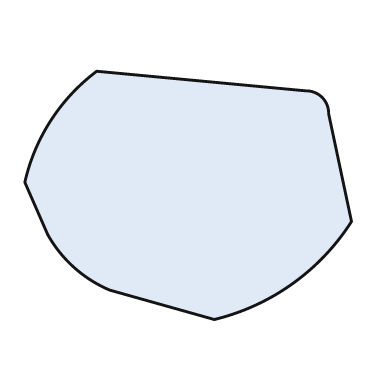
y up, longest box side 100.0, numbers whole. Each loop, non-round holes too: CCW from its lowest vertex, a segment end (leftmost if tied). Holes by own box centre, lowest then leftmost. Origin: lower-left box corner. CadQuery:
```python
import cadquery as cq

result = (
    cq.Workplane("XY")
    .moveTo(58.0, 0.0)
    .threePointArc((82.0, 11.0), (100.0, 30.0))
    .lineTo(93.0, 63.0)
    .threePointArc((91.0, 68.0), (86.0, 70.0))
    .lineTo(22.0, 76.0)
    .threePointArc((8.0, 61.0), (0.0, 42.0))
    .lineTo(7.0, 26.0)
    .threePointArc((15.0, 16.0), (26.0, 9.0))
    .close()
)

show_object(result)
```